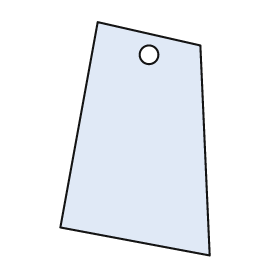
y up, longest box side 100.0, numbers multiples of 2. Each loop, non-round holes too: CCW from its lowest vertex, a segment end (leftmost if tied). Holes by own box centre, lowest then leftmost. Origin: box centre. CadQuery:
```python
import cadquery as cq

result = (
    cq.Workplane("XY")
    .moveTo(32.0, -50.0)
    .lineTo(28.0, 40.0)
    .lineTo(-16.0, 50.0)
    .lineTo(-32.0, -38.0)
    .close()
    .moveTo(6.0, 36.0)
    .circle(4.0)
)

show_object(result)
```